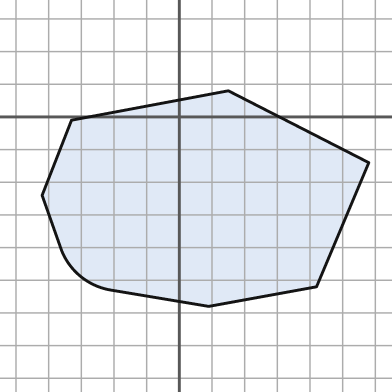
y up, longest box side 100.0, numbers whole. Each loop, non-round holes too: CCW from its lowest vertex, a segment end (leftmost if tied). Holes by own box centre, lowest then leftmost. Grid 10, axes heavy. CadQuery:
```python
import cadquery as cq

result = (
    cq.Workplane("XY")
    .moveTo(9.0, -58.0)
    .lineTo(42.0, -52.0)
    .lineTo(58.0, -14.0)
    .lineTo(15.0, 8.0)
    .lineTo(-33.0, -1.0)
    .lineTo(-42.0, -24.0)
    .lineTo(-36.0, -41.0)
    .threePointArc((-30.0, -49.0), (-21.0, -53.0))
    .close()
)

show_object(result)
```